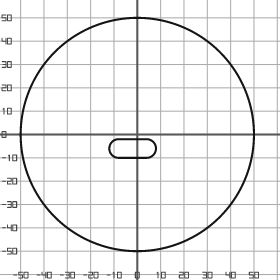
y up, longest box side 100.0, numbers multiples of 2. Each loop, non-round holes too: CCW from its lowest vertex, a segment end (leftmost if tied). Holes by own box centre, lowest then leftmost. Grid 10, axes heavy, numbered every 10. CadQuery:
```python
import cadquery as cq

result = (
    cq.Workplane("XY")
    .moveTo(0.0, 0.0)
    .circle(50.0)
    .moveTo(-8.0, -10.0)
    .lineTo(4.0, -10.0)
    .threePointArc((8.0, -6.0), (4.0, -2.0))
    .lineTo(-8.0, -2.0)
    .threePointArc((-12.0, -6.0), (-8.0, -10.0))
    .close()
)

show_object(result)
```